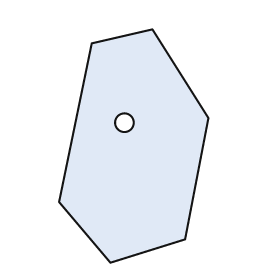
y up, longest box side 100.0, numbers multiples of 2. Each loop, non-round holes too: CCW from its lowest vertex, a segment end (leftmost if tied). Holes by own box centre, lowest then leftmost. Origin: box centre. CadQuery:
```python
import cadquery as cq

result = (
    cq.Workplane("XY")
    .moveTo(-10.0, -50.0)
    .lineTo(22.0, -40.0)
    .lineTo(32.0, 12.0)
    .lineTo(8.0, 50.0)
    .lineTo(-18.0, 44.0)
    .lineTo(-32.0, -24.0)
    .close()
    .moveTo(-4.0, 10.0)
    .circle(4.0)
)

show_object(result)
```